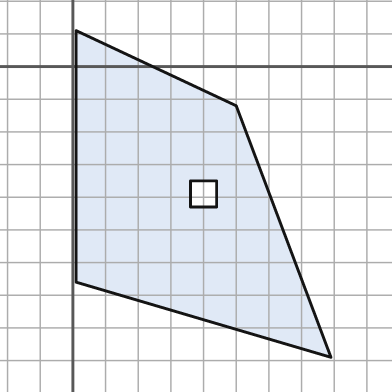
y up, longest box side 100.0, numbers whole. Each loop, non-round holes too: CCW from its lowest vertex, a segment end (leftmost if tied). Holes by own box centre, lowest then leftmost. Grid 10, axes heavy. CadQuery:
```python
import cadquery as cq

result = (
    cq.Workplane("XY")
    .moveTo(79.0, -89.0)
    .lineTo(50.0, -12.0)
    .lineTo(1.0, 11.0)
    .lineTo(1.0, -66.0)
    .close()
    .moveTo(36.0, -43.0)
    .lineTo(44.0, -43.0)
    .lineTo(44.0, -35.0)
    .lineTo(36.0, -35.0)
    .close()
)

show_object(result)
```